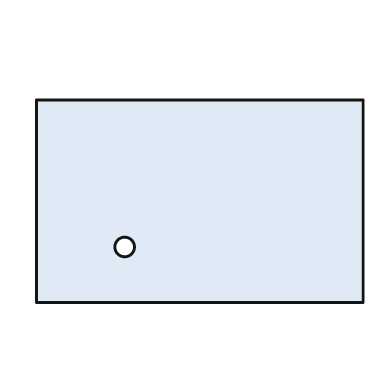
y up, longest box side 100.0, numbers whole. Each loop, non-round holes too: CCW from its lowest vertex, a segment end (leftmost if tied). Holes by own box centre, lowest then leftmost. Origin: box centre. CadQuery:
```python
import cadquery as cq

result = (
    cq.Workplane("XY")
    .moveTo(-50.0, -31.0)
    .lineTo(50.0, -31.0)
    .lineTo(50.0, 31.0)
    .lineTo(-50.0, 31.0)
    .close()
    .moveTo(-23.0, -14.0)
    .circle(3.0)
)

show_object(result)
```